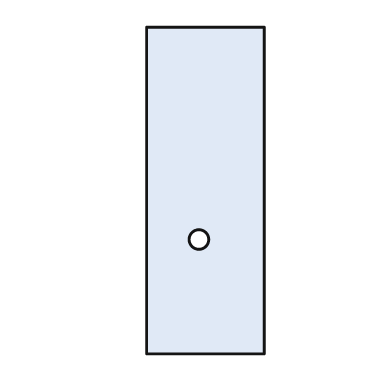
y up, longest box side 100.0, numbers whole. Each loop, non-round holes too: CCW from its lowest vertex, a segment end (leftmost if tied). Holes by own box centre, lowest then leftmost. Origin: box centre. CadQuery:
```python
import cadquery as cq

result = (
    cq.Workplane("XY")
    .moveTo(-18.0, -50.0)
    .lineTo(18.0, -50.0)
    .lineTo(18.0, 50.0)
    .lineTo(-18.0, 50.0)
    .close()
    .moveTo(-2.0, -15.0)
    .circle(3.0)
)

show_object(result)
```